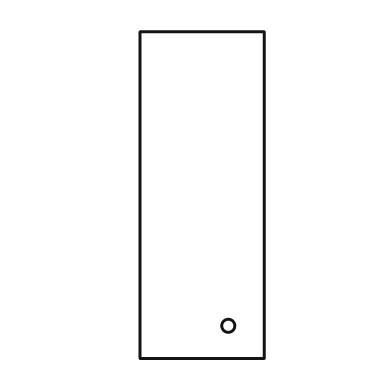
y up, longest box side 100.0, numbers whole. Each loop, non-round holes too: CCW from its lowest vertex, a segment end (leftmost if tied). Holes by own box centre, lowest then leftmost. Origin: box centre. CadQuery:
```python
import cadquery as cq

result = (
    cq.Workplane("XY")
    .moveTo(-19.0, -50.0)
    .lineTo(19.0, -50.0)
    .lineTo(19.0, 50.0)
    .lineTo(-19.0, 50.0)
    .close()
    .moveTo(8.0, -40.0)
    .circle(2.0)
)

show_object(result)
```